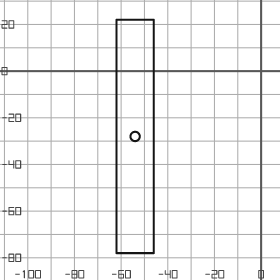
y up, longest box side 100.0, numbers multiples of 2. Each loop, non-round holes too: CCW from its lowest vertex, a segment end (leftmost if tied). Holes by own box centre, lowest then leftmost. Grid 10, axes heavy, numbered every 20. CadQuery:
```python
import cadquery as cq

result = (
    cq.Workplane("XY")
    .moveTo(-62.0, -78.0)
    .lineTo(-46.0, -78.0)
    .lineTo(-46.0, 22.0)
    .lineTo(-62.0, 22.0)
    .close()
    .moveTo(-54.0, -28.0)
    .circle(2.0)
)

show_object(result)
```